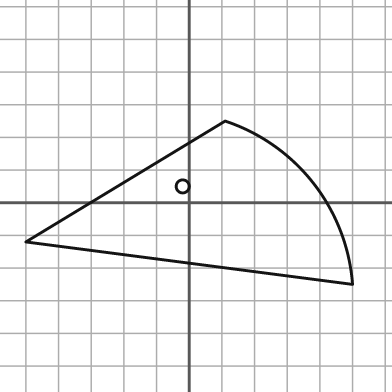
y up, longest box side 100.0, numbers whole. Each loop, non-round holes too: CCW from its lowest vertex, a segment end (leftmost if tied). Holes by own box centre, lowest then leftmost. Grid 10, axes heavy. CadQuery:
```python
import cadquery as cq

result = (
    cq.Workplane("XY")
    .moveTo(50.0, -25.0)
    .threePointArc((38.0, 6.0), (11.0, 25.0))
    .lineTo(-50.0, -12.0)
    .close()
    .moveTo(-2.0, 5.0)
    .circle(2.0)
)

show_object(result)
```